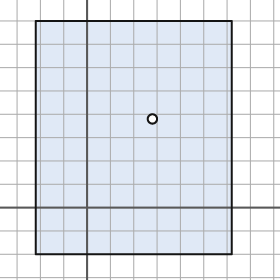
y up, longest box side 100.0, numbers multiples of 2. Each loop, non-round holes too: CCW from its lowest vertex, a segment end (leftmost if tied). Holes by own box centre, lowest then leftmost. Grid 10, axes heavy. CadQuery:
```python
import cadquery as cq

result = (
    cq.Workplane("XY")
    .moveTo(-22.0, -20.0)
    .lineTo(62.0, -20.0)
    .lineTo(62.0, 80.0)
    .lineTo(-22.0, 80.0)
    .close()
    .moveTo(28.0, 38.0)
    .circle(2.0)
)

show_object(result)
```